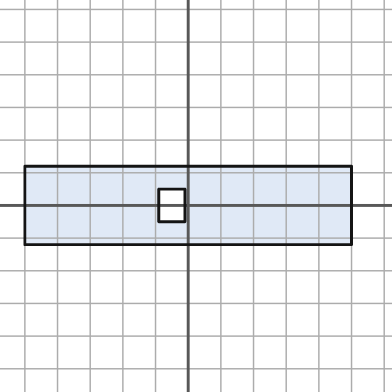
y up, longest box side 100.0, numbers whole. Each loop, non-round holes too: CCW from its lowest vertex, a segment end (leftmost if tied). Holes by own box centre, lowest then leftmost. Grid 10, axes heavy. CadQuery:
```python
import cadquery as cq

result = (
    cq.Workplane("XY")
    .moveTo(-50.0, -12.0)
    .lineTo(50.0, -12.0)
    .lineTo(50.0, 12.0)
    .lineTo(-50.0, 12.0)
    .close()
    .moveTo(-9.0, -5.0)
    .lineTo(-1.0, -5.0)
    .lineTo(-1.0, 5.0)
    .lineTo(-9.0, 5.0)
    .close()
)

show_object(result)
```